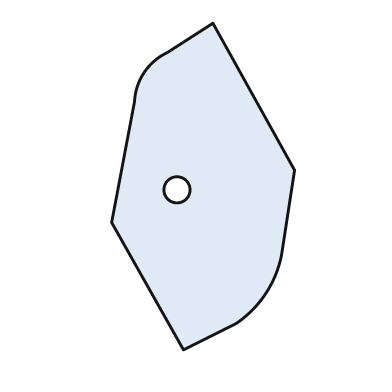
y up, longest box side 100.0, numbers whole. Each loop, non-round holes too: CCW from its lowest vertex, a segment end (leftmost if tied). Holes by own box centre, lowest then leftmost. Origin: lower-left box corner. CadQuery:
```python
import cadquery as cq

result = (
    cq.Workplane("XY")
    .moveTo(22.0, 0.0)
    .lineTo(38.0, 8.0)
    .threePointArc((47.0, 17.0), (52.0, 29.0))
    .lineTo(56.0, 55.0)
    .lineTo(31.0, 100.0)
    .lineTo(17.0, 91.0)
    .threePointArc((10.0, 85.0), (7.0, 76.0))
    .lineTo(0.0, 39.0)
    .close()
    .moveTo(20.0, 49.0)
    .circle(4.0)
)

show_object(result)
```